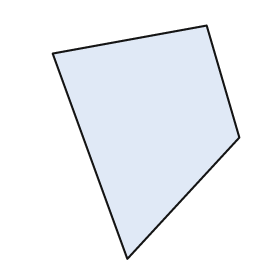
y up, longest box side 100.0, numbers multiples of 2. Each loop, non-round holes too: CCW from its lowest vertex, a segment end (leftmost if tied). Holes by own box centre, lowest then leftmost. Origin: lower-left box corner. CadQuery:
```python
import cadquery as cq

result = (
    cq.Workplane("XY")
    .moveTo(32.0, 0.0)
    .lineTo(80.0, 52.0)
    .lineTo(66.0, 100.0)
    .lineTo(0.0, 88.0)
    .close()
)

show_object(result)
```